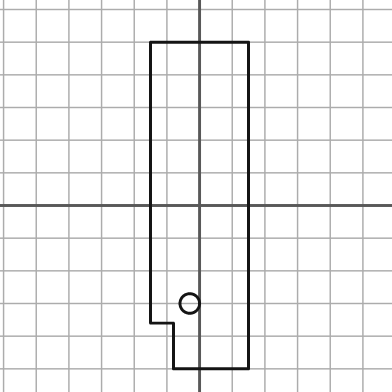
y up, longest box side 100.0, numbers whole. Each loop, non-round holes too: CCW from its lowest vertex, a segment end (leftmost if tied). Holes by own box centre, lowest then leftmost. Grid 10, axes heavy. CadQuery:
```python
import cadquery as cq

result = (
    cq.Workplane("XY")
    .moveTo(-8.0, -50.0)
    .lineTo(15.0, -50.0)
    .lineTo(15.0, 50.0)
    .lineTo(-15.0, 50.0)
    .lineTo(-15.0, -36.0)
    .lineTo(-8.0, -36.0)
    .close()
    .moveTo(-3.0, -30.0)
    .circle(3.0)
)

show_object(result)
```